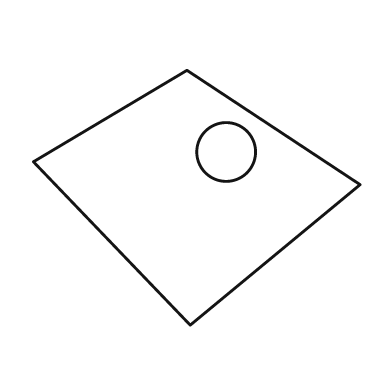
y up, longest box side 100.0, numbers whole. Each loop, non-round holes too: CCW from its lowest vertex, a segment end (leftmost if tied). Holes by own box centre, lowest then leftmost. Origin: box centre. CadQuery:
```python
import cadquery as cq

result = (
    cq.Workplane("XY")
    .moveTo(-2.0, -39.0)
    .lineTo(50.0, 4.0)
    .lineTo(-3.0, 39.0)
    .lineTo(-50.0, 11.0)
    .close()
    .moveTo(9.0, 14.0)
    .circle(9.0)
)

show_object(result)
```